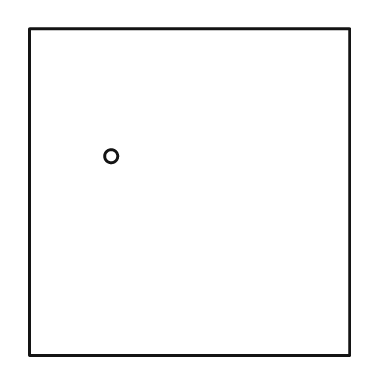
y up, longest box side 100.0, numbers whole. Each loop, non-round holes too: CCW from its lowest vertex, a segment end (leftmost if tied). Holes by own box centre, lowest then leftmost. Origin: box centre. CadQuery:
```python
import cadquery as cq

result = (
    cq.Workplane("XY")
    .moveTo(-49.0, -50.0)
    .lineTo(49.0, -50.0)
    .lineTo(49.0, 50.0)
    .lineTo(-49.0, 50.0)
    .close()
    .moveTo(-24.0, 11.0)
    .circle(2.0)
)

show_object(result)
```